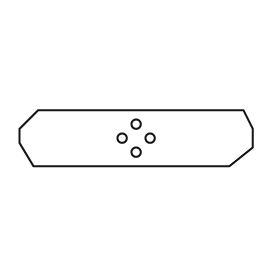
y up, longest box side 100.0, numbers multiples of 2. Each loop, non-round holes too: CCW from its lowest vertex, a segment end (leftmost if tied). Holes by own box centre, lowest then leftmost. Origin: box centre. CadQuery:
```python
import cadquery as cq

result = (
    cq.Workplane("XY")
    .moveTo(-44.0, -12.0)
    .lineTo(40.0, -12.0)
    .lineTo(50.0, -4.0)
    .lineTo(50.0, 4.0)
    .lineTo(46.0, 12.0)
    .lineTo(-42.0, 12.0)
    .lineTo(-50.0, 4.0)
    .lineTo(-50.0, -2.0)
    .close()
    .moveTo(0.0, -6.0)
    .circle(2.0)
    .moveTo(-6.0, 0.0)
    .circle(2.0)
    .moveTo(6.0, 0.0)
    .circle(2.0)
    .moveTo(0.0, 6.0)
    .circle(2.0)
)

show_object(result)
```